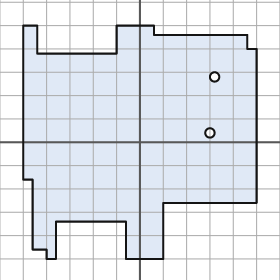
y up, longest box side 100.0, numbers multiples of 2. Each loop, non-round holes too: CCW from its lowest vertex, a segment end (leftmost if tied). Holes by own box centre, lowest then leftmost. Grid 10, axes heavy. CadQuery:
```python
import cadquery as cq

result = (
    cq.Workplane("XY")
    .moveTo(-40.0, -50.0)
    .lineTo(-36.0, -50.0)
    .lineTo(-36.0, -34.0)
    .lineTo(-6.0, -34.0)
    .lineTo(-6.0, -50.0)
    .lineTo(10.0, -50.0)
    .lineTo(10.0, -26.0)
    .lineTo(50.0, -26.0)
    .lineTo(50.0, 40.0)
    .lineTo(46.0, 40.0)
    .lineTo(46.0, 46.0)
    .lineTo(6.0, 46.0)
    .lineTo(6.0, 50.0)
    .lineTo(-10.0, 50.0)
    .lineTo(-10.0, 38.0)
    .lineTo(-44.0, 38.0)
    .lineTo(-44.0, 50.0)
    .lineTo(-50.0, 50.0)
    .lineTo(-50.0, -16.0)
    .lineTo(-46.0, -16.0)
    .lineTo(-46.0, -46.0)
    .lineTo(-40.0, -46.0)
    .close()
    .moveTo(30.0, 4.0)
    .circle(2.0)
    .moveTo(32.0, 28.0)
    .circle(2.0)
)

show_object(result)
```